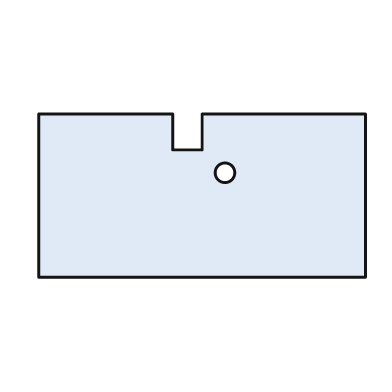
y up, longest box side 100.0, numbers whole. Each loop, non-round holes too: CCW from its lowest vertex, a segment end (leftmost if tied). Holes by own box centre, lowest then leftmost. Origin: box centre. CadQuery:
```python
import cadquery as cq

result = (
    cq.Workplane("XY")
    .moveTo(-50.0, -25.0)
    .lineTo(50.0, -25.0)
    .lineTo(50.0, 25.0)
    .lineTo(0.0, 25.0)
    .lineTo(0.0, 14.0)
    .lineTo(-9.0, 14.0)
    .lineTo(-9.0, 25.0)
    .lineTo(-50.0, 25.0)
    .close()
    .moveTo(7.0, 7.0)
    .circle(3.0)
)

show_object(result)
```